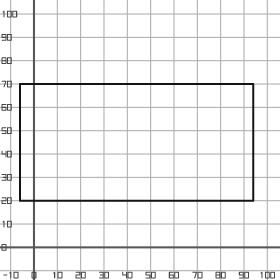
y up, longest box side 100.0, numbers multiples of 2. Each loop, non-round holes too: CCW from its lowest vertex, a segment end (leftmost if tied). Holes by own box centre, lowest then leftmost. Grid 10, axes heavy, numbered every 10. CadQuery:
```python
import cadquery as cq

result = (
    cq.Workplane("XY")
    .moveTo(-6.0, 20.0)
    .lineTo(94.0, 20.0)
    .lineTo(94.0, 70.0)
    .lineTo(-6.0, 70.0)
    .close()
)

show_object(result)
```